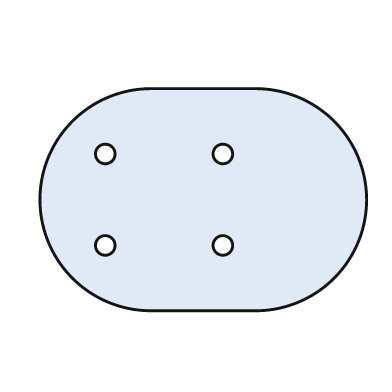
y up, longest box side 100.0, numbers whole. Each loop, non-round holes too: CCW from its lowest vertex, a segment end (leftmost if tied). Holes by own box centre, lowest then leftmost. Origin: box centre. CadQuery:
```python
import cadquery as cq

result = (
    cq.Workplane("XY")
    .moveTo(-16.0, -34.0)
    .lineTo(16.0, -34.0)
    .threePointArc((50.0, 0.0), (16.0, 34.0))
    .lineTo(-16.0, 34.0)
    .threePointArc((-50.0, 0.0), (-16.0, -34.0))
    .close()
    .moveTo(-30.0, -14.0)
    .circle(3.0)
    .moveTo(6.0, -14.0)
    .circle(3.0)
    .moveTo(-30.0, 14.0)
    .circle(3.0)
    .moveTo(6.0, 14.0)
    .circle(3.0)
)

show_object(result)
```